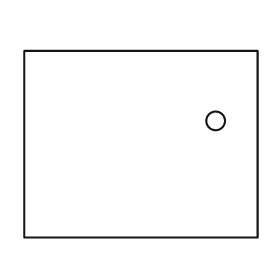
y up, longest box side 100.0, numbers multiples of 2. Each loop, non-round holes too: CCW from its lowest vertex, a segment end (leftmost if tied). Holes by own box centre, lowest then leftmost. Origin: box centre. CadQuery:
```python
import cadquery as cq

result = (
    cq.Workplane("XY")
    .moveTo(-50.0, -40.0)
    .lineTo(50.0, -40.0)
    .lineTo(50.0, 40.0)
    .lineTo(-50.0, 40.0)
    .close()
    .moveTo(32.0, 10.0)
    .circle(4.0)
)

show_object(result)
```